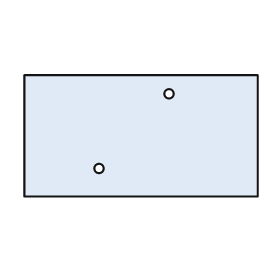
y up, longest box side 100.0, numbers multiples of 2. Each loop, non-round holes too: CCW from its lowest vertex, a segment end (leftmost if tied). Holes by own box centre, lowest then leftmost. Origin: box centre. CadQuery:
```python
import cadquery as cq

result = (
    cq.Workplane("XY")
    .moveTo(-50.0, -26.0)
    .lineTo(50.0, -26.0)
    .lineTo(50.0, 26.0)
    .lineTo(-50.0, 26.0)
    .close()
    .moveTo(-18.0, -14.0)
    .circle(2.0)
    .moveTo(12.0, 18.0)
    .circle(2.0)
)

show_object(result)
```